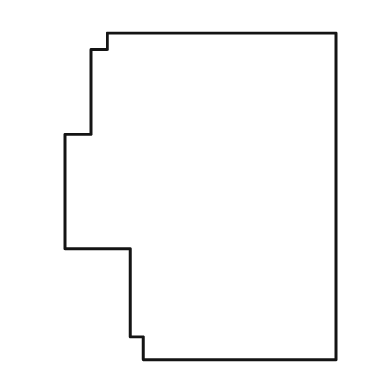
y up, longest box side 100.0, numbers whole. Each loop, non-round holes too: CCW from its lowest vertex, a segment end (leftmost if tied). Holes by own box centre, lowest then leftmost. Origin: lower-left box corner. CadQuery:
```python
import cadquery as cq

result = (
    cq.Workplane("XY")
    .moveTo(24.0, 0.0)
    .lineTo(83.0, 0.0)
    .lineTo(83.0, 100.0)
    .lineTo(13.0, 100.0)
    .lineTo(13.0, 95.0)
    .lineTo(8.0, 95.0)
    .lineTo(8.0, 69.0)
    .lineTo(0.0, 69.0)
    .lineTo(0.0, 34.0)
    .lineTo(20.0, 34.0)
    .lineTo(20.0, 7.0)
    .lineTo(24.0, 7.0)
    .close()
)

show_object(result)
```